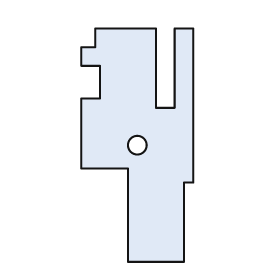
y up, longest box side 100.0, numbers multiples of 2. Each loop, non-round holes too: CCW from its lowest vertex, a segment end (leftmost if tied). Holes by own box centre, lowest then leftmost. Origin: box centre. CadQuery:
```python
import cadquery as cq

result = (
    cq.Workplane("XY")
    .moveTo(-4.0, -50.0)
    .lineTo(20.0, -50.0)
    .lineTo(20.0, -16.0)
    .lineTo(24.0, -16.0)
    .lineTo(24.0, 50.0)
    .lineTo(16.0, 50.0)
    .lineTo(16.0, 16.0)
    .lineTo(8.0, 16.0)
    .lineTo(8.0, 50.0)
    .lineTo(-18.0, 50.0)
    .lineTo(-18.0, 42.0)
    .lineTo(-24.0, 42.0)
    .lineTo(-24.0, 34.0)
    .lineTo(-16.0, 34.0)
    .lineTo(-16.0, 20.0)
    .lineTo(-24.0, 20.0)
    .lineTo(-24.0, -10.0)
    .lineTo(-4.0, -10.0)
    .close()
    .moveTo(0.0, 0.0)
    .circle(4.0)
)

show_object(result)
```